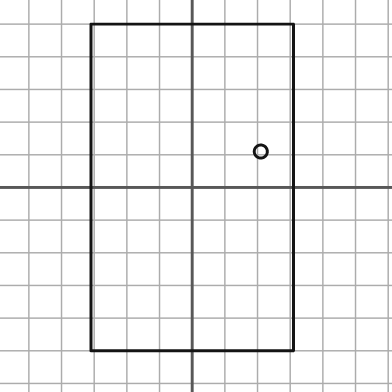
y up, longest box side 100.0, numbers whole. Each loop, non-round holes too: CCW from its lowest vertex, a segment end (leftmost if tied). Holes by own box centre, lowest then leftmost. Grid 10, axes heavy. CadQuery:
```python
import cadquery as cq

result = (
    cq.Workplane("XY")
    .moveTo(-31.0, -50.0)
    .lineTo(31.0, -50.0)
    .lineTo(31.0, 50.0)
    .lineTo(-31.0, 50.0)
    .close()
    .moveTo(21.0, 11.0)
    .circle(2.0)
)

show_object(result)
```